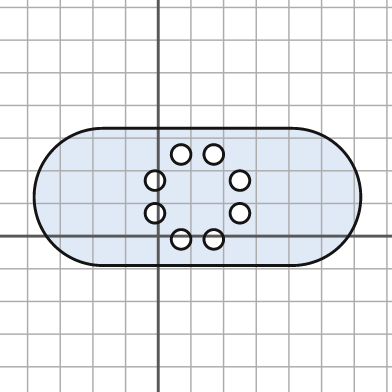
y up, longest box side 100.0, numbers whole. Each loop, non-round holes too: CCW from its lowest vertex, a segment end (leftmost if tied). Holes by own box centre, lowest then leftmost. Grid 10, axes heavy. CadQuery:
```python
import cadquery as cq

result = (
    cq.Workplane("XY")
    .moveTo(-17.0, -9.0)
    .lineTo(41.0, -9.0)
    .threePointArc((62.0, 12.0), (41.0, 33.0))
    .lineTo(-17.0, 33.0)
    .threePointArc((-38.0, 12.0), (-17.0, -9.0))
    .close()
    .moveTo(7.0, -1.0)
    .circle(3.0)
    .moveTo(17.0, -1.0)
    .circle(3.0)
    .moveTo(-1.0, 7.0)
    .circle(3.0)
    .moveTo(25.0, 7.0)
    .circle(3.0)
    .moveTo(-1.0, 17.0)
    .circle(3.0)
    .moveTo(25.0, 17.0)
    .circle(3.0)
    .moveTo(7.0, 25.0)
    .circle(3.0)
    .moveTo(17.0, 25.0)
    .circle(3.0)
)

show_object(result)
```